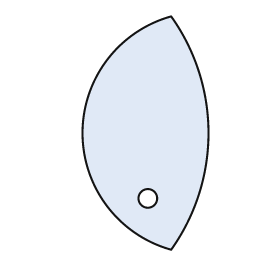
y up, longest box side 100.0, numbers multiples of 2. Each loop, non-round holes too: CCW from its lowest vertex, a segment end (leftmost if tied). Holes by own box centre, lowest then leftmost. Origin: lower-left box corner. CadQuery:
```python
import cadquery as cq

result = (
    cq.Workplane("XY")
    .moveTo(38.0, 0.0)
    .threePointArc((54.0, 50.0), (38.0, 100.0))
    .threePointArc((0.0, 50.0), (38.0, 0.0))
    .close()
    .moveTo(28.0, 22.0)
    .circle(4.0)
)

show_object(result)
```